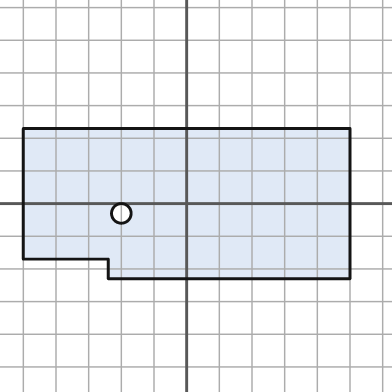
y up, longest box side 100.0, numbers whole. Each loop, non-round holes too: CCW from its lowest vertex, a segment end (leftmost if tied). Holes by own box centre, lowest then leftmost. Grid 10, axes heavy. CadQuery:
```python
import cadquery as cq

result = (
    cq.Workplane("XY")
    .moveTo(-24.0, -23.0)
    .lineTo(50.0, -23.0)
    .lineTo(50.0, 23.0)
    .lineTo(-50.0, 23.0)
    .lineTo(-50.0, -17.0)
    .lineTo(-24.0, -17.0)
    .close()
    .moveTo(-20.0, -3.0)
    .circle(3.0)
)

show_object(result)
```